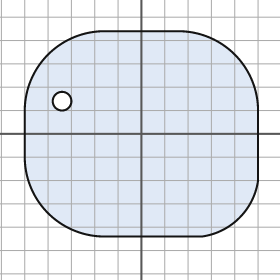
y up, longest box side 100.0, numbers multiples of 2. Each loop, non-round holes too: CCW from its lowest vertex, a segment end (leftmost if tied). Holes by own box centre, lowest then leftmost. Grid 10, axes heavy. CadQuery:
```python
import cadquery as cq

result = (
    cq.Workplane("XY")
    .moveTo(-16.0, -44.0)
    .lineTo(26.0, -44.0)
    .threePointArc((42.0, -36.0), (50.0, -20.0))
    .lineTo(50.0, 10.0)
    .threePointArc((40.0, 34.0), (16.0, 44.0))
    .lineTo(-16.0, 44.0)
    .threePointArc((-40.0, 34.0), (-50.0, 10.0))
    .lineTo(-50.0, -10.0)
    .threePointArc((-40.0, -34.0), (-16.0, -44.0))
    .close()
    .moveTo(-34.0, 14.0)
    .circle(4.0)
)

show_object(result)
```